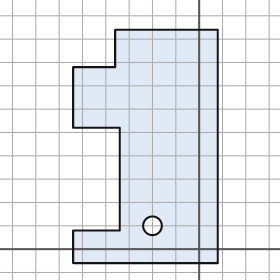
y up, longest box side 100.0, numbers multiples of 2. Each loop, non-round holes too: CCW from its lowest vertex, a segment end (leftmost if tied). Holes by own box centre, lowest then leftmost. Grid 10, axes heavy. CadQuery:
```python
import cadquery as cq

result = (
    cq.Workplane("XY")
    .moveTo(-54.0, -6.0)
    .lineTo(8.0, -6.0)
    .lineTo(8.0, 94.0)
    .lineTo(-36.0, 94.0)
    .lineTo(-36.0, 78.0)
    .lineTo(-54.0, 78.0)
    .lineTo(-54.0, 52.0)
    .lineTo(-34.0, 52.0)
    .lineTo(-34.0, 8.0)
    .lineTo(-54.0, 8.0)
    .close()
    .moveTo(-20.0, 10.0)
    .circle(4.0)
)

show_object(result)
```